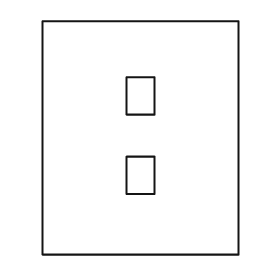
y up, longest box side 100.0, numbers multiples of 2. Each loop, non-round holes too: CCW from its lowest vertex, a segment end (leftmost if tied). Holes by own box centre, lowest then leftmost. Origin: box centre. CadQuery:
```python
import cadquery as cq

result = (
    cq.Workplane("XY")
    .moveTo(-42.0, -50.0)
    .lineTo(42.0, -50.0)
    .lineTo(42.0, 50.0)
    .lineTo(-42.0, 50.0)
    .close()
    .moveTo(-6.0, -24.0)
    .lineTo(6.0, -24.0)
    .lineTo(6.0, -8.0)
    .lineTo(-6.0, -8.0)
    .close()
    .moveTo(-6.0, 10.0)
    .lineTo(6.0, 10.0)
    .lineTo(6.0, 26.0)
    .lineTo(-6.0, 26.0)
    .close()
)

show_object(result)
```